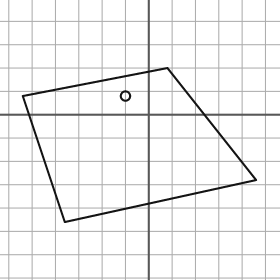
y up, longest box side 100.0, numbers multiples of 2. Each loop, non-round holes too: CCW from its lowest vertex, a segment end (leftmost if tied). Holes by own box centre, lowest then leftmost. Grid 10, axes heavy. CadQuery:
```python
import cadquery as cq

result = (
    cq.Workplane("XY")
    .moveTo(-36.0, -46.0)
    .lineTo(46.0, -28.0)
    .lineTo(8.0, 20.0)
    .lineTo(-54.0, 8.0)
    .close()
    .moveTo(-10.0, 8.0)
    .circle(2.0)
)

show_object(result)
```